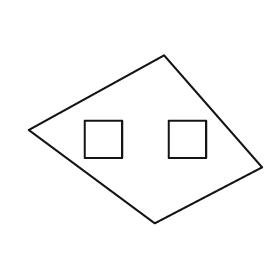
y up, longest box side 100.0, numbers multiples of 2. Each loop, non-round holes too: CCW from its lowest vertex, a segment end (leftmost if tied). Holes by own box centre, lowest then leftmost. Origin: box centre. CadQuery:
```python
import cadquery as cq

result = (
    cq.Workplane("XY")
    .moveTo(4.0, -36.0)
    .lineTo(50.0, -12.0)
    .lineTo(8.0, 36.0)
    .lineTo(-50.0, 4.0)
    .close()
    .moveTo(-26.0, -8.0)
    .lineTo(-10.0, -8.0)
    .lineTo(-10.0, 8.0)
    .lineTo(-26.0, 8.0)
    .close()
    .moveTo(10.0, -8.0)
    .lineTo(26.0, -8.0)
    .lineTo(26.0, 8.0)
    .lineTo(10.0, 8.0)
    .close()
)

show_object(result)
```